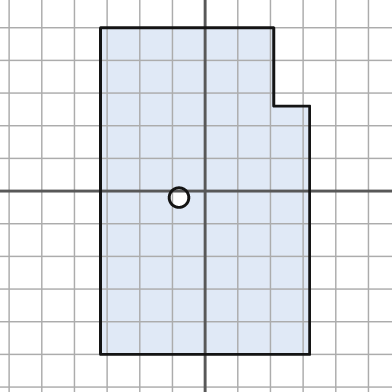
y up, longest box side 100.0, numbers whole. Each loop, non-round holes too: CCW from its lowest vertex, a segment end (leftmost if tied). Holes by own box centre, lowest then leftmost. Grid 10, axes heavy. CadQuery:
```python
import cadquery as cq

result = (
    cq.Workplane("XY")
    .moveTo(-32.0, -50.0)
    .lineTo(32.0, -50.0)
    .lineTo(32.0, 26.0)
    .lineTo(21.0, 26.0)
    .lineTo(21.0, 50.0)
    .lineTo(-32.0, 50.0)
    .close()
    .moveTo(-8.0, -2.0)
    .circle(3.0)
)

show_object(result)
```